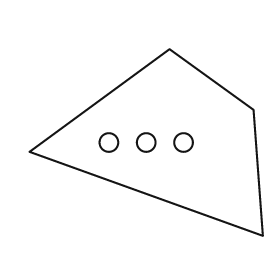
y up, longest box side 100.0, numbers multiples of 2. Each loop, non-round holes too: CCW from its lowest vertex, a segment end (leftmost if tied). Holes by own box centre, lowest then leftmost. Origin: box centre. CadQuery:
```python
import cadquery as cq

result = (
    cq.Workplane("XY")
    .moveTo(50.0, -40.0)
    .lineTo(46.0, 14.0)
    .lineTo(10.0, 40.0)
    .lineTo(-50.0, -4.0)
    .close()
    .moveTo(-16.0, 0.0)
    .circle(4.0)
    .moveTo(0.0, 0.0)
    .circle(4.0)
    .moveTo(16.0, 0.0)
    .circle(4.0)
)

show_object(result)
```